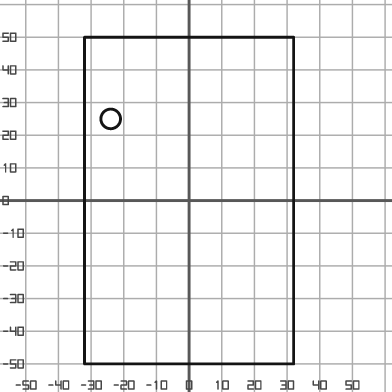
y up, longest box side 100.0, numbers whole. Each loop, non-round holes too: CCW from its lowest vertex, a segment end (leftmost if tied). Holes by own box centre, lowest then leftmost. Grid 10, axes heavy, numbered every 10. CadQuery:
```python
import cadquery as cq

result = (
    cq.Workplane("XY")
    .moveTo(-32.0, -50.0)
    .lineTo(32.0, -50.0)
    .lineTo(32.0, 50.0)
    .lineTo(-32.0, 50.0)
    .close()
    .moveTo(-24.0, 25.0)
    .circle(3.0)
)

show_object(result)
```